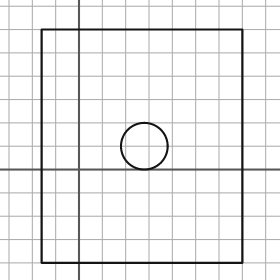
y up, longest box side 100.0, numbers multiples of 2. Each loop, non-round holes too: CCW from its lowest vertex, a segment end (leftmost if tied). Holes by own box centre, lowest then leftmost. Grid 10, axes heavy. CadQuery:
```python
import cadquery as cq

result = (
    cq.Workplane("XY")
    .moveTo(-16.0, -40.0)
    .lineTo(70.0, -40.0)
    .lineTo(70.0, 60.0)
    .lineTo(-16.0, 60.0)
    .close()
    .moveTo(28.0, 10.0)
    .circle(10.0)
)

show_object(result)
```